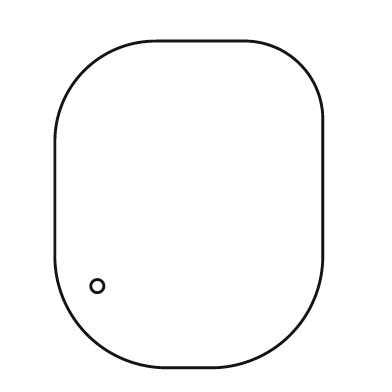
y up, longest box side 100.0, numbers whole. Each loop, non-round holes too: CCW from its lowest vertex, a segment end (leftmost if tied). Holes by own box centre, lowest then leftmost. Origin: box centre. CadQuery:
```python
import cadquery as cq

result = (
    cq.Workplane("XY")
    .moveTo(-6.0, -50.0)
    .lineTo(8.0, -50.0)
    .threePointArc((31.0, -40.0), (41.0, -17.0))
    .lineTo(41.0, 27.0)
    .threePointArc((34.0, 43.0), (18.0, 50.0))
    .lineTo(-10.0, 50.0)
    .threePointArc((-32.0, 41.0), (-41.0, 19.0))
    .lineTo(-41.0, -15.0)
    .threePointArc((-31.0, -40.0), (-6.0, -50.0))
    .close()
    .moveTo(-28.0, -25.0)
    .circle(2.0)
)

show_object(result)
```